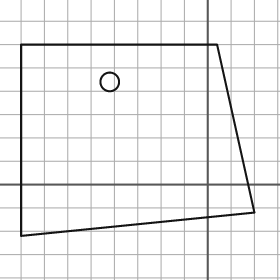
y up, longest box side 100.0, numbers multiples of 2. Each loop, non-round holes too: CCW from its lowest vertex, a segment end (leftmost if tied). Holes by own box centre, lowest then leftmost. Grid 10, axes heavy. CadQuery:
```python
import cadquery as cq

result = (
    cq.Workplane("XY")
    .moveTo(-80.0, -22.0)
    .lineTo(20.0, -12.0)
    .lineTo(4.0, 60.0)
    .lineTo(-80.0, 60.0)
    .close()
    .moveTo(-42.0, 44.0)
    .circle(4.0)
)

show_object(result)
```